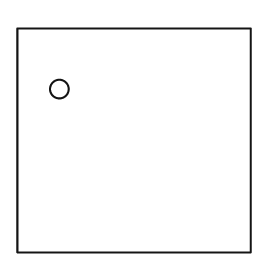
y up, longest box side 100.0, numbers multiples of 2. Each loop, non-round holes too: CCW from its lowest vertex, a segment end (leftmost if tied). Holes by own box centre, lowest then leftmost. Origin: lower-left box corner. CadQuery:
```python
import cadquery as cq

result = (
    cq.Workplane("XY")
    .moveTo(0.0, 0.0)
    .lineTo(100.0, 0.0)
    .lineTo(100.0, 96.0)
    .lineTo(0.0, 96.0)
    .close()
    .moveTo(18.0, 70.0)
    .circle(4.0)
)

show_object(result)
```